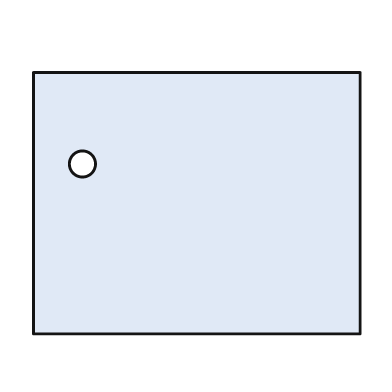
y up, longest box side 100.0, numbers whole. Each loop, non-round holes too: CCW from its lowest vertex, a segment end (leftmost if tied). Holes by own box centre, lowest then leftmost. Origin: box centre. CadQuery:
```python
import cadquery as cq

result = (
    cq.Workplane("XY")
    .moveTo(-50.0, -40.0)
    .lineTo(50.0, -40.0)
    .lineTo(50.0, 40.0)
    .lineTo(-50.0, 40.0)
    .close()
    .moveTo(-35.0, 12.0)
    .circle(4.0)
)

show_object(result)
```